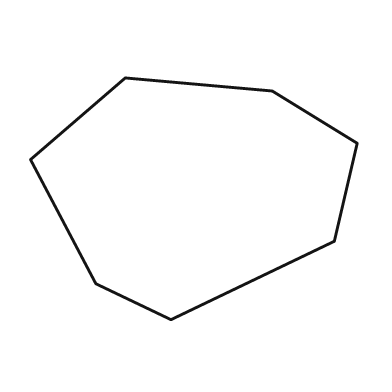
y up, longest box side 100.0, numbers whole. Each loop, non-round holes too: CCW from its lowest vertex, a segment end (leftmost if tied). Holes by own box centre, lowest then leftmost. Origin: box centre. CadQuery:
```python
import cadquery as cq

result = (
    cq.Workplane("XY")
    .moveTo(-7.0, -37.0)
    .lineTo(43.0, -13.0)
    .lineTo(50.0, 17.0)
    .lineTo(24.0, 33.0)
    .lineTo(-21.0, 37.0)
    .lineTo(-50.0, 12.0)
    .lineTo(-30.0, -26.0)
    .close()
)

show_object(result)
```